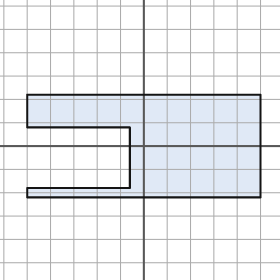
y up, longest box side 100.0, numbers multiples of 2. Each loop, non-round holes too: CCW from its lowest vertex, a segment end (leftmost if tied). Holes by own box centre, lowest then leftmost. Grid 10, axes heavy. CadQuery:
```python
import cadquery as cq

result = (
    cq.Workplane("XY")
    .moveTo(-50.0, -22.0)
    .lineTo(50.0, -22.0)
    .lineTo(50.0, 22.0)
    .lineTo(-50.0, 22.0)
    .lineTo(-50.0, 8.0)
    .lineTo(-6.0, 8.0)
    .lineTo(-6.0, -18.0)
    .lineTo(-50.0, -18.0)
    .close()
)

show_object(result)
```